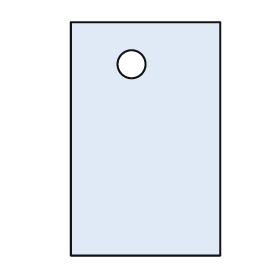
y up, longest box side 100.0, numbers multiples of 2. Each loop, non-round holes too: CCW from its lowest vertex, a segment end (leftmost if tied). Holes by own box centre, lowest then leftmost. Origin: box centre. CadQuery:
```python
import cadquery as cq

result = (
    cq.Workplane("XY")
    .moveTo(-32.0, -50.0)
    .lineTo(32.0, -50.0)
    .lineTo(32.0, 50.0)
    .lineTo(-32.0, 50.0)
    .close()
    .moveTo(-6.0, 32.0)
    .circle(6.0)
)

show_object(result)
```